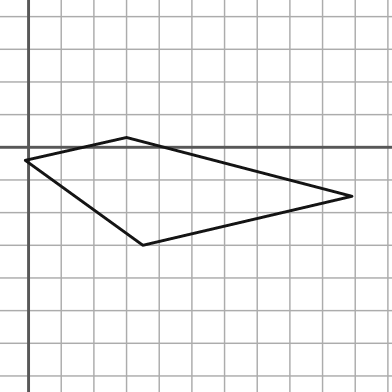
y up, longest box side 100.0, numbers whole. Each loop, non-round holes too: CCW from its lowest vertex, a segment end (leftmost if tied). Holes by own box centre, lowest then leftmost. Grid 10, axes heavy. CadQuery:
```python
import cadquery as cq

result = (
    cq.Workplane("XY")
    .moveTo(35.0, -30.0)
    .lineTo(99.0, -15.0)
    .lineTo(30.0, 3.0)
    .lineTo(-1.0, -4.0)
    .close()
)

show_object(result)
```